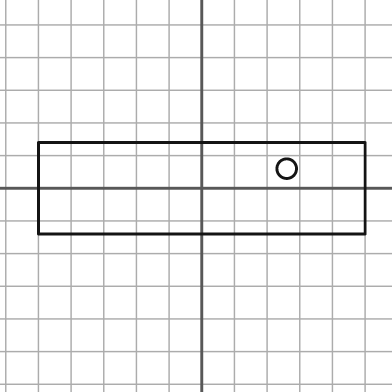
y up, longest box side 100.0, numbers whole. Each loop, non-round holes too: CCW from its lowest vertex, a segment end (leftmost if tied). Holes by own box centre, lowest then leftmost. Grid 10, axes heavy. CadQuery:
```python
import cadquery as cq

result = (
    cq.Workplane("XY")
    .moveTo(-50.0, -14.0)
    .lineTo(50.0, -14.0)
    .lineTo(50.0, 14.0)
    .lineTo(-50.0, 14.0)
    .close()
    .moveTo(26.0, 6.0)
    .circle(3.0)
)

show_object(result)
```